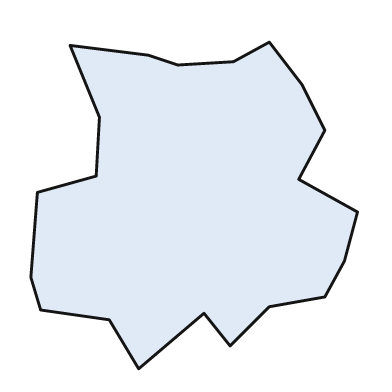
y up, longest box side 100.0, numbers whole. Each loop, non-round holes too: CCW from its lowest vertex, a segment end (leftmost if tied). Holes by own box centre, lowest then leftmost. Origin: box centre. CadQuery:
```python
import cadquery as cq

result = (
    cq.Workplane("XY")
    .moveTo(-17.0, -50.0)
    .lineTo(3.0, -33.0)
    .lineTo(11.0, -43.0)
    .lineTo(23.0, -31.0)
    .lineTo(40.0, -28.0)
    .lineTo(46.0, -17.0)
    .lineTo(50.0, -2.0)
    .lineTo(32.0, 8.0)
    .lineTo(40.0, 23.0)
    .lineTo(33.0, 37.0)
    .lineTo(23.0, 50.0)
    .lineTo(12.0, 44.0)
    .lineTo(-5.0, 43.0)
    .lineTo(-14.0, 46.0)
    .lineTo(-38.0, 49.0)
    .lineTo(-29.0, 27.0)
    .lineTo(-30.0, 9.0)
    .lineTo(-48.0, 4.0)
    .lineTo(-50.0, -22.0)
    .lineTo(-47.0, -32.0)
    .lineTo(-26.0, -35.0)
    .close()
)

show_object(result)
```